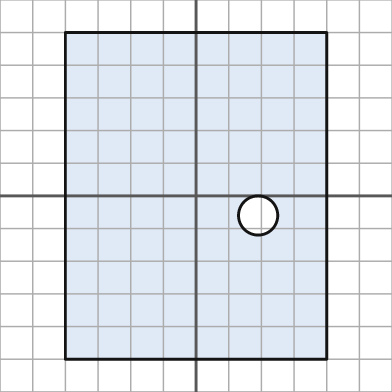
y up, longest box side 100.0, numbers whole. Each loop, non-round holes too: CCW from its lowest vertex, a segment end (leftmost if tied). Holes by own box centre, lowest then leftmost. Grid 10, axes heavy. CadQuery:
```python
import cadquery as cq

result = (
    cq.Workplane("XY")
    .moveTo(-40.0, -50.0)
    .lineTo(40.0, -50.0)
    .lineTo(40.0, 50.0)
    .lineTo(-40.0, 50.0)
    .close()
    .moveTo(19.0, -6.0)
    .circle(6.0)
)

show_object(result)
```